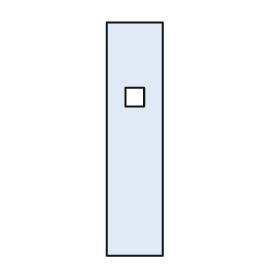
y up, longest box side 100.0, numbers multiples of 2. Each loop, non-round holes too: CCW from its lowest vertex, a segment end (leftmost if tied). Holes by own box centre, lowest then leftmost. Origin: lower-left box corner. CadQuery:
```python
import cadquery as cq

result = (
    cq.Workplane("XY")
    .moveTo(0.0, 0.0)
    .lineTo(24.0, 0.0)
    .lineTo(24.0, 100.0)
    .lineTo(0.0, 100.0)
    .close()
    .moveTo(8.0, 64.0)
    .lineTo(16.0, 64.0)
    .lineTo(16.0, 72.0)
    .lineTo(8.0, 72.0)
    .close()
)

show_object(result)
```